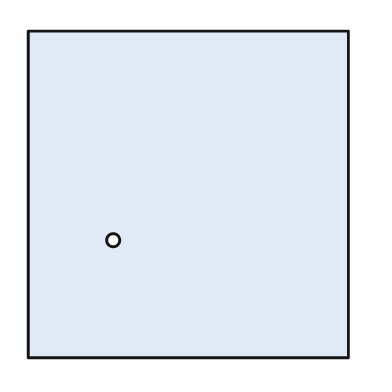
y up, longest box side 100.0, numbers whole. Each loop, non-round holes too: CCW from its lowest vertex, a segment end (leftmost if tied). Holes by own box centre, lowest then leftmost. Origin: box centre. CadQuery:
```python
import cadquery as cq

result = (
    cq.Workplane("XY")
    .moveTo(-49.0, -50.0)
    .lineTo(49.0, -50.0)
    .lineTo(49.0, 50.0)
    .lineTo(-49.0, 50.0)
    .close()
    .moveTo(-23.0, -14.0)
    .circle(2.0)
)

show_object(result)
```